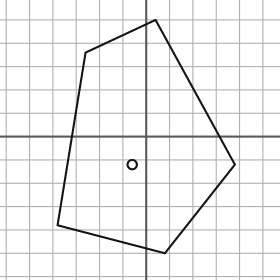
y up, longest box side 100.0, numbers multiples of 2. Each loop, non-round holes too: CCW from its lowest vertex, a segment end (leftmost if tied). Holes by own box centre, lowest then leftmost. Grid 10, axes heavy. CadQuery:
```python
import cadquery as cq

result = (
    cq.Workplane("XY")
    .moveTo(8.0, -50.0)
    .lineTo(38.0, -12.0)
    .lineTo(4.0, 50.0)
    .lineTo(-26.0, 36.0)
    .lineTo(-38.0, -38.0)
    .close()
    .moveTo(-6.0, -12.0)
    .circle(2.0)
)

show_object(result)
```